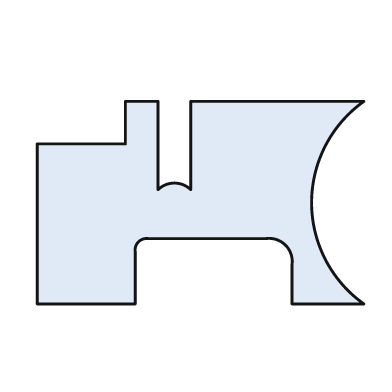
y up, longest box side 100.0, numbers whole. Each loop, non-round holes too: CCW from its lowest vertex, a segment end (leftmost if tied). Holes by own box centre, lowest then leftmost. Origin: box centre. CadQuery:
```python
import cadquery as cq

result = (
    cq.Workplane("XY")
    .moveTo(-50.0, -31.0)
    .lineTo(-20.0, -31.0)
    .lineTo(-20.0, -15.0)
    .threePointArc((-19.0, -12.0), (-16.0, -11.0))
    .lineTo(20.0, -11.0)
    .threePointArc((26.0, -13.0), (28.0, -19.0))
    .lineTo(28.0, -31.0)
    .lineTo(50.0, -31.0)
    .threePointArc((34.0, 0.0), (50.0, 31.0))
    .lineTo(-3.0, 31.0)
    .lineTo(-3.0, 4.0)
    .threePointArc((-8.0, 6.0), (-13.0, 4.0))
    .lineTo(-13.0, 31.0)
    .lineTo(-23.0, 31.0)
    .lineTo(-23.0, 18.0)
    .lineTo(-50.0, 18.0)
    .close()
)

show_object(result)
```